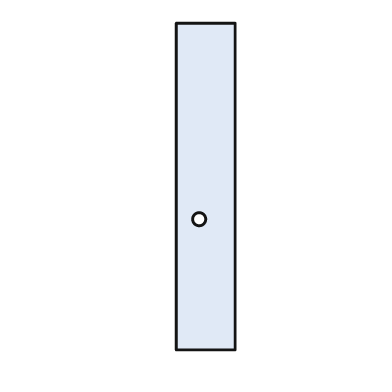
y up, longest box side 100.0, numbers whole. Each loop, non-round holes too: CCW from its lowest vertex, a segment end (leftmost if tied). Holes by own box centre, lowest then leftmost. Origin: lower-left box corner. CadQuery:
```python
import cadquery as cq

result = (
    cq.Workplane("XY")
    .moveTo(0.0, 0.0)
    .lineTo(18.0, 0.0)
    .lineTo(18.0, 100.0)
    .lineTo(0.0, 100.0)
    .close()
    .moveTo(7.0, 40.0)
    .circle(2.0)
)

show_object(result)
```